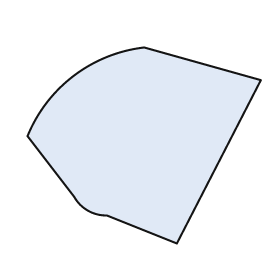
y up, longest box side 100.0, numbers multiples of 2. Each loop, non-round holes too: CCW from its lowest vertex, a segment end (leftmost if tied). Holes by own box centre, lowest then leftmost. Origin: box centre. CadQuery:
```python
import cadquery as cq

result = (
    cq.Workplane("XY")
    .moveTo(14.0, -42.0)
    .lineTo(50.0, 28.0)
    .lineTo(0.0, 42.0)
    .threePointArc((-30.0, 30.0), (-50.0, 4.0))
    .lineTo(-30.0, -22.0)
    .threePointArc((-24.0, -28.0), (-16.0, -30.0))
    .close()
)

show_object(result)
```